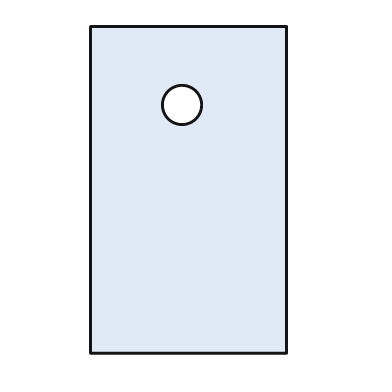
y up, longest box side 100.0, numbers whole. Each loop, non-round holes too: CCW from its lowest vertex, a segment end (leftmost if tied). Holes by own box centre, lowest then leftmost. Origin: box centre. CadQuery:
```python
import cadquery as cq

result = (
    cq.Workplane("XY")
    .moveTo(-30.0, -50.0)
    .lineTo(30.0, -50.0)
    .lineTo(30.0, 50.0)
    .lineTo(-30.0, 50.0)
    .close()
    .moveTo(-2.0, 26.0)
    .circle(6.0)
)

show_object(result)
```